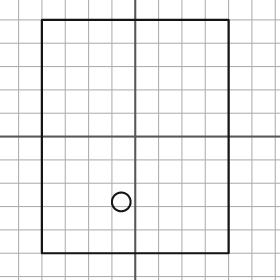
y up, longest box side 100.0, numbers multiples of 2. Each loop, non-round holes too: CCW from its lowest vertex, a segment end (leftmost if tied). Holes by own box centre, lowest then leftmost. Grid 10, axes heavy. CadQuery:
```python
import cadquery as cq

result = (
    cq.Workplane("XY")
    .moveTo(-40.0, -50.0)
    .lineTo(40.0, -50.0)
    .lineTo(40.0, 50.0)
    .lineTo(-40.0, 50.0)
    .close()
    .moveTo(-6.0, -28.0)
    .circle(4.0)
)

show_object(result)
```